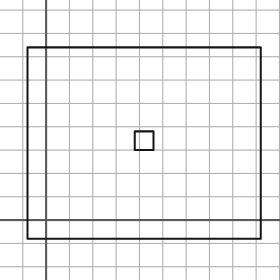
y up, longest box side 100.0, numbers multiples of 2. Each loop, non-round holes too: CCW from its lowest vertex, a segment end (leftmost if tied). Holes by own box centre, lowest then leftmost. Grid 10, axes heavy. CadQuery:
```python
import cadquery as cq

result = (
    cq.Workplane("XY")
    .moveTo(-8.0, -8.0)
    .lineTo(92.0, -8.0)
    .lineTo(92.0, 74.0)
    .lineTo(-8.0, 74.0)
    .close()
    .moveTo(38.0, 30.0)
    .lineTo(46.0, 30.0)
    .lineTo(46.0, 38.0)
    .lineTo(38.0, 38.0)
    .close()
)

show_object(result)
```